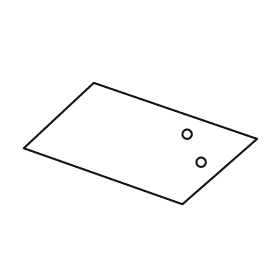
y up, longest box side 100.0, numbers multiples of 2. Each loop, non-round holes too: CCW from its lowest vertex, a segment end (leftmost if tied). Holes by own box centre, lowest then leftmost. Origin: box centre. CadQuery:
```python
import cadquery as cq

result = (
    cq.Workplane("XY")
    .moveTo(18.0, -26.0)
    .lineTo(50.0, 2.0)
    .lineTo(-20.0, 26.0)
    .lineTo(-50.0, -2.0)
    .close()
    .moveTo(26.0, -8.0)
    .circle(2.0)
    .moveTo(20.0, 4.0)
    .circle(2.0)
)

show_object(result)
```